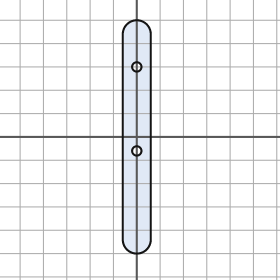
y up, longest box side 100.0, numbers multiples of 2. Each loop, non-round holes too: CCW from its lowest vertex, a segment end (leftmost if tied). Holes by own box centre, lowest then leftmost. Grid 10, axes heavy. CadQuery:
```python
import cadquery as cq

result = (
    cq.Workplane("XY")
    .moveTo(-6.0, -44.0)
    .threePointArc((0.0, -50.0), (6.0, -44.0))
    .lineTo(6.0, 44.0)
    .threePointArc((0.0, 50.0), (-6.0, 44.0))
    .close()
    .moveTo(0.0, -6.0)
    .circle(2.0)
    .moveTo(0.0, 30.0)
    .circle(2.0)
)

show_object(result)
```